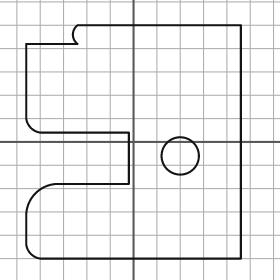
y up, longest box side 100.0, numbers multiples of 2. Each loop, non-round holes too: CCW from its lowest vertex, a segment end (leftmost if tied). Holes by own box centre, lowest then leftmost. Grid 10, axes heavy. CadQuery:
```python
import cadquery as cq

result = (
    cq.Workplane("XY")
    .moveTo(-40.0, -50.0)
    .lineTo(46.0, -50.0)
    .lineTo(46.0, 50.0)
    .lineTo(-24.0, 50.0)
    .threePointArc((-26.0, 46.0), (-24.0, 42.0))
    .lineTo(-46.0, 42.0)
    .lineTo(-46.0, 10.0)
    .threePointArc((-44.0, 6.0), (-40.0, 4.0))
    .lineTo(-2.0, 4.0)
    .lineTo(-2.0, -18.0)
    .lineTo(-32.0, -18.0)
    .threePointArc((-42.0, -22.0), (-46.0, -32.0))
    .lineTo(-46.0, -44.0)
    .threePointArc((-44.0, -48.0), (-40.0, -50.0))
    .close()
    .moveTo(20.0, -6.0)
    .circle(8.0)
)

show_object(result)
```